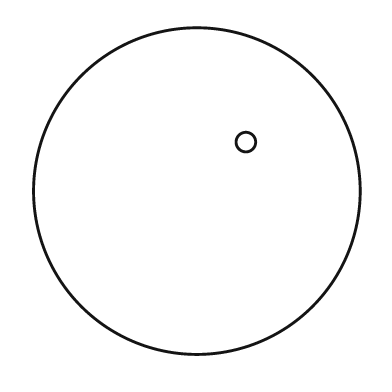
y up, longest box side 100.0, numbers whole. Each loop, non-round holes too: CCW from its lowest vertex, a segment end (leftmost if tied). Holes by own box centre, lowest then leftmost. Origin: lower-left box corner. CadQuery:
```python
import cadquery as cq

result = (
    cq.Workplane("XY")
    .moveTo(50.0, 50.0)
    .circle(50.0)
    .moveTo(65.0, 65.0)
    .circle(3.0)
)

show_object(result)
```